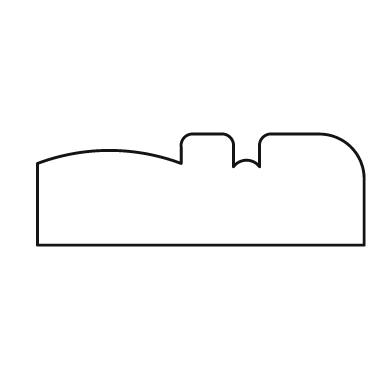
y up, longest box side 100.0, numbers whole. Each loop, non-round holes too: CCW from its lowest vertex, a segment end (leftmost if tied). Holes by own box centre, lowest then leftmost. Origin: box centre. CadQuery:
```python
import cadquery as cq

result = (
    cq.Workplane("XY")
    .moveTo(-50.0, -17.0)
    .lineTo(50.0, -17.0)
    .lineTo(50.0, 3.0)
    .threePointArc((46.0, 13.0), (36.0, 17.0))
    .lineTo(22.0, 17.0)
    .threePointArc((19.0, 16.0), (18.0, 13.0))
    .lineTo(18.0, 7.0)
    .threePointArc((14.0, 9.0), (10.0, 7.0))
    .lineTo(10.0, 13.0)
    .threePointArc((9.0, 16.0), (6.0, 17.0))
    .lineTo(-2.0, 17.0)
    .threePointArc((-5.0, 16.0), (-6.0, 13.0))
    .lineTo(-6.0, 8.0)
    .threePointArc((-28.0, 12.0), (-50.0, 8.0))
    .close()
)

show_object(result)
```